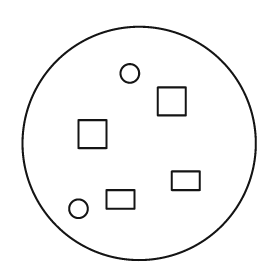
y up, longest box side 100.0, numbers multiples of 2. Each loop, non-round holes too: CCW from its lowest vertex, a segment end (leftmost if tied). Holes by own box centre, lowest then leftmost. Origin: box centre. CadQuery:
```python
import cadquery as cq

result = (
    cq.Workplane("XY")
    .moveTo(0.0, 0.0)
    .circle(50.0)
    .moveTo(-26.0, -28.0)
    .circle(4.0)
    .moveTo(-14.0, -28.0)
    .lineTo(-2.0, -28.0)
    .lineTo(-2.0, -20.0)
    .lineTo(-14.0, -20.0)
    .close()
    .moveTo(14.0, -20.0)
    .lineTo(26.0, -20.0)
    .lineTo(26.0, -12.0)
    .lineTo(14.0, -12.0)
    .close()
    .moveTo(-26.0, -2.0)
    .lineTo(-14.0, -2.0)
    .lineTo(-14.0, 10.0)
    .lineTo(-26.0, 10.0)
    .close()
    .moveTo(8.0, 12.0)
    .lineTo(20.0, 12.0)
    .lineTo(20.0, 24.0)
    .lineTo(8.0, 24.0)
    .close()
    .moveTo(-4.0, 30.0)
    .circle(4.0)
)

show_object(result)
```